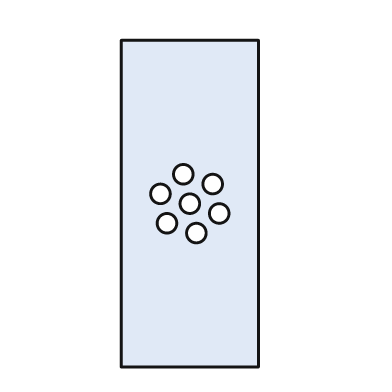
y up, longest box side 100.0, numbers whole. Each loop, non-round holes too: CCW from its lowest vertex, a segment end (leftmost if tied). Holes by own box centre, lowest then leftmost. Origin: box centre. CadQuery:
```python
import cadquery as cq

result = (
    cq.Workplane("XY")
    .moveTo(-21.0, -50.0)
    .lineTo(21.0, -50.0)
    .lineTo(21.0, 50.0)
    .lineTo(-21.0, 50.0)
    .close()
    .moveTo(2.0, -9.0)
    .circle(3.0)
    .moveTo(-7.0, -6.0)
    .circle(3.0)
    .moveTo(9.0, -3.0)
    .circle(3.0)
    .moveTo(0.0, 0.0)
    .circle(3.0)
    .moveTo(-9.0, 3.0)
    .circle(3.0)
    .moveTo(7.0, 6.0)
    .circle(3.0)
    .moveTo(-2.0, 9.0)
    .circle(3.0)
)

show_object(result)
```